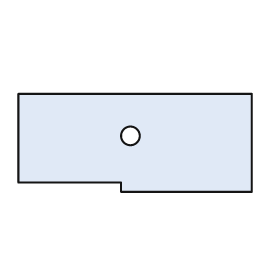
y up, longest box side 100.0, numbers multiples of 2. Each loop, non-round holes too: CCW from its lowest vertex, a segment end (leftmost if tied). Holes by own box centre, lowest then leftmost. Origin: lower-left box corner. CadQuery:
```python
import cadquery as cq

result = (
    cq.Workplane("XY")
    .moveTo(44.0, 0.0)
    .lineTo(100.0, 0.0)
    .lineTo(100.0, 42.0)
    .lineTo(0.0, 42.0)
    .lineTo(0.0, 4.0)
    .lineTo(44.0, 4.0)
    .close()
    .moveTo(48.0, 24.0)
    .circle(4.0)
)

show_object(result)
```